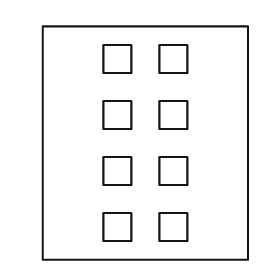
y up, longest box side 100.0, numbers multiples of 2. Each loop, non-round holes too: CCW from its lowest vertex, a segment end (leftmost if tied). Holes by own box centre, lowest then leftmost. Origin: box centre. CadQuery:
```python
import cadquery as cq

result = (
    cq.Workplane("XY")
    .moveTo(-44.0, -50.0)
    .lineTo(44.0, -50.0)
    .lineTo(44.0, 50.0)
    .lineTo(-44.0, 50.0)
    .close()
    .moveTo(-18.0, -42.0)
    .lineTo(-6.0, -42.0)
    .lineTo(-6.0, -30.0)
    .lineTo(-18.0, -30.0)
    .close()
    .moveTo(6.0, -42.0)
    .lineTo(18.0, -42.0)
    .lineTo(18.0, -30.0)
    .lineTo(6.0, -30.0)
    .close()
    .moveTo(-18.0, -18.0)
    .lineTo(-6.0, -18.0)
    .lineTo(-6.0, -6.0)
    .lineTo(-18.0, -6.0)
    .close()
    .moveTo(6.0, -18.0)
    .lineTo(18.0, -18.0)
    .lineTo(18.0, -6.0)
    .lineTo(6.0, -6.0)
    .close()
    .moveTo(-18.0, 6.0)
    .lineTo(-6.0, 6.0)
    .lineTo(-6.0, 18.0)
    .lineTo(-18.0, 18.0)
    .close()
    .moveTo(6.0, 6.0)
    .lineTo(18.0, 6.0)
    .lineTo(18.0, 18.0)
    .lineTo(6.0, 18.0)
    .close()
    .moveTo(-18.0, 30.0)
    .lineTo(-6.0, 30.0)
    .lineTo(-6.0, 42.0)
    .lineTo(-18.0, 42.0)
    .close()
    .moveTo(6.0, 30.0)
    .lineTo(18.0, 30.0)
    .lineTo(18.0, 42.0)
    .lineTo(6.0, 42.0)
    .close()
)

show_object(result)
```